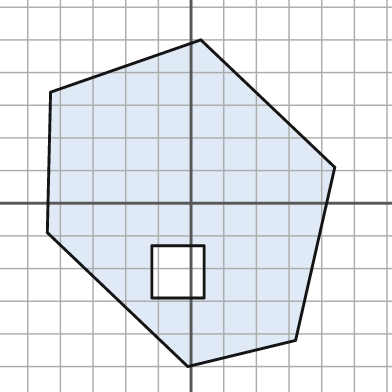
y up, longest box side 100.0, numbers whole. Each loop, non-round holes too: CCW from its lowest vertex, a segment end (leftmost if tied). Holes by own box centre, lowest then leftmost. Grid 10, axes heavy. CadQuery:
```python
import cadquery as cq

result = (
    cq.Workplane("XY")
    .moveTo(-1.0, -50.0)
    .lineTo(32.0, -42.0)
    .lineTo(44.0, 11.0)
    .lineTo(3.0, 50.0)
    .lineTo(-43.0, 34.0)
    .lineTo(-44.0, -9.0)
    .close()
    .moveTo(-12.0, -29.0)
    .lineTo(4.0, -29.0)
    .lineTo(4.0, -13.0)
    .lineTo(-12.0, -13.0)
    .close()
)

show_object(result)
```